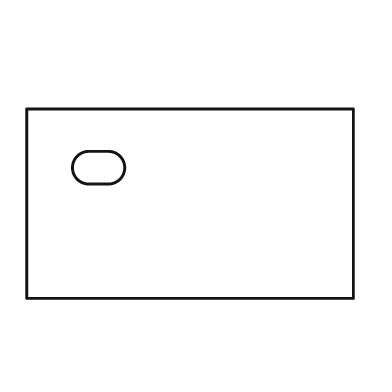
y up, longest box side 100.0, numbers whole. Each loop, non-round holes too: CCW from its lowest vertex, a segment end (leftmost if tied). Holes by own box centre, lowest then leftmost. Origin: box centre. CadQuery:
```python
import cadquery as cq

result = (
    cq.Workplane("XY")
    .moveTo(-50.0, -29.0)
    .lineTo(50.0, -29.0)
    .lineTo(50.0, 29.0)
    .lineTo(-50.0, 29.0)
    .close()
    .moveTo(-31.0, 6.0)
    .lineTo(-25.0, 6.0)
    .threePointArc((-20.0, 11.0), (-25.0, 16.0))
    .lineTo(-31.0, 16.0)
    .threePointArc((-36.0, 11.0), (-31.0, 6.0))
    .close()
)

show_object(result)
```